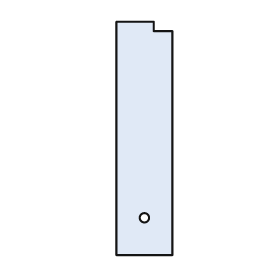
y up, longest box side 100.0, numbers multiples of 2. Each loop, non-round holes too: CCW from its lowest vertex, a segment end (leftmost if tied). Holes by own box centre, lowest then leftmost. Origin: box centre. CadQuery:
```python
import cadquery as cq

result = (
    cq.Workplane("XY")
    .moveTo(-12.0, -50.0)
    .lineTo(12.0, -50.0)
    .lineTo(12.0, 46.0)
    .lineTo(4.0, 46.0)
    .lineTo(4.0, 50.0)
    .lineTo(-12.0, 50.0)
    .close()
    .moveTo(0.0, -34.0)
    .circle(2.0)
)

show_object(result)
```